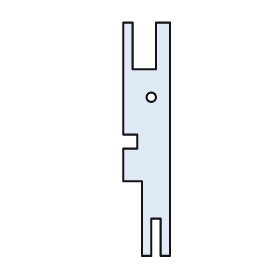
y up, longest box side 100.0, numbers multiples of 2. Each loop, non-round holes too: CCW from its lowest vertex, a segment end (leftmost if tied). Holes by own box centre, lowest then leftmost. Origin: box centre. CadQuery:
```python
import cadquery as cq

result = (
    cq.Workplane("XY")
    .moveTo(-2.0, -50.0)
    .lineTo(2.0, -50.0)
    .lineTo(2.0, -34.0)
    .lineTo(6.0, -34.0)
    .lineTo(6.0, -50.0)
    .lineTo(10.0, -50.0)
    .lineTo(10.0, 50.0)
    .lineTo(4.0, 50.0)
    .lineTo(4.0, 30.0)
    .lineTo(-6.0, 30.0)
    .lineTo(-6.0, 50.0)
    .lineTo(-10.0, 50.0)
    .lineTo(-10.0, 2.0)
    .lineTo(-4.0, 2.0)
    .lineTo(-4.0, -4.0)
    .lineTo(-10.0, -4.0)
    .lineTo(-10.0, -18.0)
    .lineTo(-2.0, -18.0)
    .close()
    .moveTo(2.0, 18.0)
    .circle(2.0)
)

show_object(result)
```